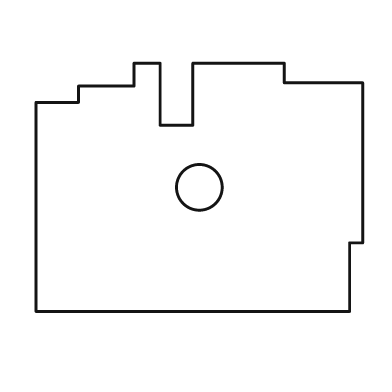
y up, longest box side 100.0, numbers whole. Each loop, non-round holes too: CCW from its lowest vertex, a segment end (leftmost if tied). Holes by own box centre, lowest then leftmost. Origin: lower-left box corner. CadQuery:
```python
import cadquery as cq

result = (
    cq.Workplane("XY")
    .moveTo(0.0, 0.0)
    .lineTo(96.0, 0.0)
    .lineTo(96.0, 21.0)
    .lineTo(100.0, 21.0)
    .lineTo(100.0, 70.0)
    .lineTo(76.0, 70.0)
    .lineTo(76.0, 76.0)
    .lineTo(48.0, 76.0)
    .lineTo(48.0, 57.0)
    .lineTo(38.0, 57.0)
    .lineTo(38.0, 76.0)
    .lineTo(30.0, 76.0)
    .lineTo(30.0, 69.0)
    .lineTo(13.0, 69.0)
    .lineTo(13.0, 64.0)
    .lineTo(0.0, 64.0)
    .close()
    .moveTo(50.0, 38.0)
    .circle(7.0)
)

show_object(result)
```